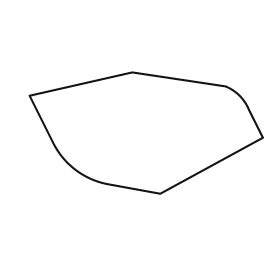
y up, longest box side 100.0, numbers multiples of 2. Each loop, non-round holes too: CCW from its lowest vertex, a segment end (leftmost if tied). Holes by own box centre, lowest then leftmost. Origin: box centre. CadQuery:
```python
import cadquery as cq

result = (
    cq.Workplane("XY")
    .moveTo(6.0, -26.0)
    .lineTo(50.0, -2.0)
    .lineTo(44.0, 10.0)
    .threePointArc((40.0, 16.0), (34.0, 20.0))
    .lineTo(-6.0, 26.0)
    .lineTo(-50.0, 16.0)
    .lineTo(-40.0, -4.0)
    .threePointArc((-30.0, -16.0), (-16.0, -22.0))
    .close()
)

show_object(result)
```